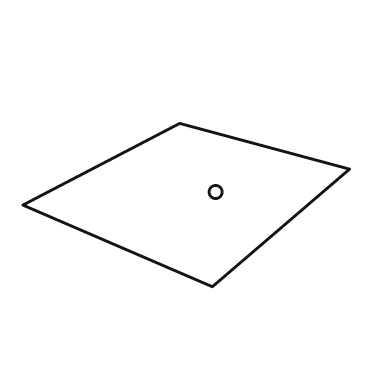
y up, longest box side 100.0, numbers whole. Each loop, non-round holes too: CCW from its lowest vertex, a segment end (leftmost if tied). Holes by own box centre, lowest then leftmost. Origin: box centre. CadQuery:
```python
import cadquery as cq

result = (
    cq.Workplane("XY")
    .moveTo(8.0, -25.0)
    .lineTo(50.0, 11.0)
    .lineTo(-2.0, 25.0)
    .lineTo(-50.0, 0.0)
    .close()
    .moveTo(9.0, 4.0)
    .circle(2.0)
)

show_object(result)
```